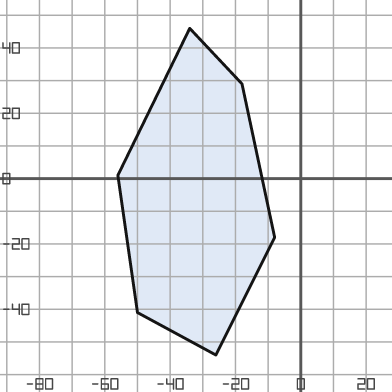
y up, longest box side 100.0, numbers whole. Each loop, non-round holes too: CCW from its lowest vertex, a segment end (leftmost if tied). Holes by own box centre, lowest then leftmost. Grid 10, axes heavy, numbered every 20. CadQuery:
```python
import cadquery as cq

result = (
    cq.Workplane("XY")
    .moveTo(-26.0, -54.0)
    .lineTo(-8.0, -18.0)
    .lineTo(-18.0, 29.0)
    .lineTo(-34.0, 46.0)
    .lineTo(-56.0, 1.0)
    .lineTo(-50.0, -41.0)
    .close()
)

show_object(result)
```